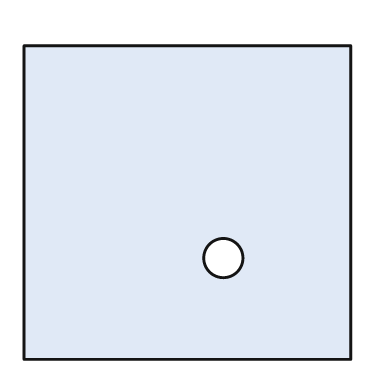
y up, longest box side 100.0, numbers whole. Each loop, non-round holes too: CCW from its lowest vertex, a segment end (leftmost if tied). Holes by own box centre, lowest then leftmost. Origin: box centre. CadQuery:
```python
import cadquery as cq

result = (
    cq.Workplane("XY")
    .moveTo(-50.0, -48.0)
    .lineTo(50.0, -48.0)
    .lineTo(50.0, 48.0)
    .lineTo(-50.0, 48.0)
    .close()
    .moveTo(11.0, -17.0)
    .circle(6.0)
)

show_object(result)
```